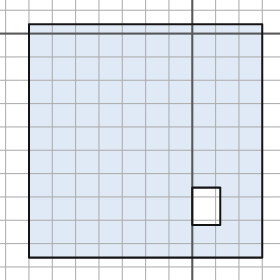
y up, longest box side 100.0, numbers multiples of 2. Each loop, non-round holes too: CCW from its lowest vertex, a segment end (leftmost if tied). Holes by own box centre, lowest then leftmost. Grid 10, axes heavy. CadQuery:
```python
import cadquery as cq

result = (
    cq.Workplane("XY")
    .moveTo(-70.0, -96.0)
    .lineTo(30.0, -96.0)
    .lineTo(30.0, 4.0)
    .lineTo(-70.0, 4.0)
    .close()
    .moveTo(0.0, -82.0)
    .lineTo(12.0, -82.0)
    .lineTo(12.0, -66.0)
    .lineTo(0.0, -66.0)
    .close()
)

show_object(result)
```